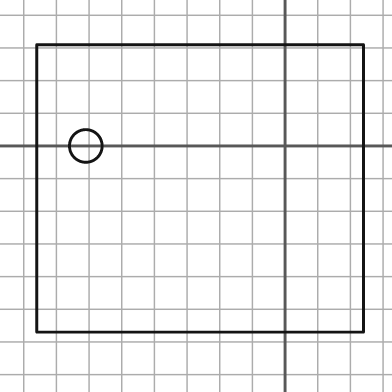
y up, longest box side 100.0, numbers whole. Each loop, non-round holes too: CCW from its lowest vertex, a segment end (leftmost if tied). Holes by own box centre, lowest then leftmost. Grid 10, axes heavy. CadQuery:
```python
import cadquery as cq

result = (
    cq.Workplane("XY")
    .moveTo(-76.0, -57.0)
    .lineTo(24.0, -57.0)
    .lineTo(24.0, 31.0)
    .lineTo(-76.0, 31.0)
    .close()
    .moveTo(-61.0, 0.0)
    .circle(5.0)
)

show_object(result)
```